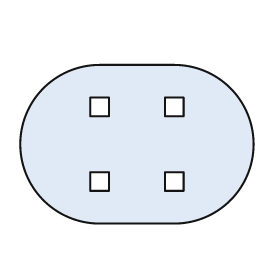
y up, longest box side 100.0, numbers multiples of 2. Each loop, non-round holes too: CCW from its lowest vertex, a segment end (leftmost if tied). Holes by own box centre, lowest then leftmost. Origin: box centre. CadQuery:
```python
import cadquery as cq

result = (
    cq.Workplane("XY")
    .moveTo(-16.0, -34.0)
    .lineTo(16.0, -34.0)
    .threePointArc((50.0, 0.0), (16.0, 34.0))
    .lineTo(-16.0, 34.0)
    .threePointArc((-50.0, 0.0), (-16.0, -34.0))
    .close()
    .moveTo(-20.0, -20.0)
    .lineTo(-12.0, -20.0)
    .lineTo(-12.0, -12.0)
    .lineTo(-20.0, -12.0)
    .close()
    .moveTo(12.0, -20.0)
    .lineTo(20.0, -20.0)
    .lineTo(20.0, -12.0)
    .lineTo(12.0, -12.0)
    .close()
    .moveTo(-20.0, 12.0)
    .lineTo(-12.0, 12.0)
    .lineTo(-12.0, 20.0)
    .lineTo(-20.0, 20.0)
    .close()
    .moveTo(12.0, 12.0)
    .lineTo(20.0, 12.0)
    .lineTo(20.0, 20.0)
    .lineTo(12.0, 20.0)
    .close()
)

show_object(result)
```